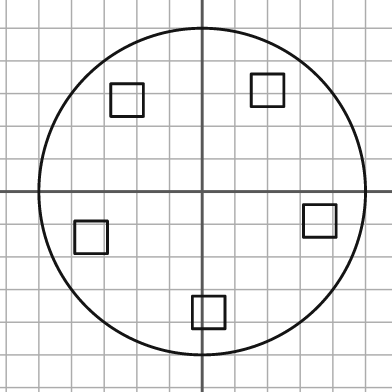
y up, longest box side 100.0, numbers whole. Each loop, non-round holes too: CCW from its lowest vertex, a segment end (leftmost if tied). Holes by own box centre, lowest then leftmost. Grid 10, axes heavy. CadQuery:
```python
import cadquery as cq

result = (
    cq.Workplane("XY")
    .moveTo(0.0, 0.0)
    .circle(50.0)
    .moveTo(-3.0, -42.0)
    .lineTo(7.0, -42.0)
    .lineTo(7.0, -32.0)
    .lineTo(-3.0, -32.0)
    .close()
    .moveTo(-39.0, -19.0)
    .lineTo(-29.0, -19.0)
    .lineTo(-29.0, -9.0)
    .lineTo(-39.0, -9.0)
    .close()
    .moveTo(31.0, -14.0)
    .lineTo(41.0, -14.0)
    .lineTo(41.0, -4.0)
    .lineTo(31.0, -4.0)
    .close()
    .moveTo(-28.0, 23.0)
    .lineTo(-18.0, 23.0)
    .lineTo(-18.0, 33.0)
    .lineTo(-28.0, 33.0)
    .close()
    .moveTo(15.0, 26.0)
    .lineTo(25.0, 26.0)
    .lineTo(25.0, 36.0)
    .lineTo(15.0, 36.0)
    .close()
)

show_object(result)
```